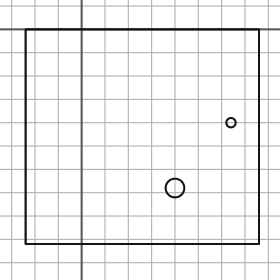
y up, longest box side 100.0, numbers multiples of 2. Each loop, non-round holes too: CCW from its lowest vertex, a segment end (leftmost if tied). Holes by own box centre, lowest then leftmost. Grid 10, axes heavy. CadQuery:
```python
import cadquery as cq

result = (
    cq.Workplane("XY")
    .moveTo(-24.0, -92.0)
    .lineTo(76.0, -92.0)
    .lineTo(76.0, 0.0)
    .lineTo(-24.0, 0.0)
    .close()
    .moveTo(40.0, -68.0)
    .circle(4.0)
    .moveTo(64.0, -40.0)
    .circle(2.0)
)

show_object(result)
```